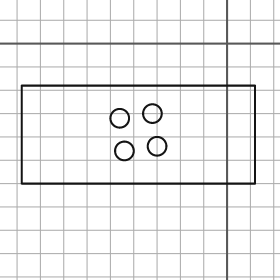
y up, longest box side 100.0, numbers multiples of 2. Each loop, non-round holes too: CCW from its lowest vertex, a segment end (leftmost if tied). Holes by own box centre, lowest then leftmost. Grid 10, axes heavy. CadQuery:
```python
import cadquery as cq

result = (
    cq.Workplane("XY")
    .moveTo(-88.0, -60.0)
    .lineTo(12.0, -60.0)
    .lineTo(12.0, -18.0)
    .lineTo(-88.0, -18.0)
    .close()
    .moveTo(-44.0, -46.0)
    .circle(4.0)
    .moveTo(-30.0, -44.0)
    .circle(4.0)
    .moveTo(-46.0, -32.0)
    .circle(4.0)
    .moveTo(-32.0, -30.0)
    .circle(4.0)
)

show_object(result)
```